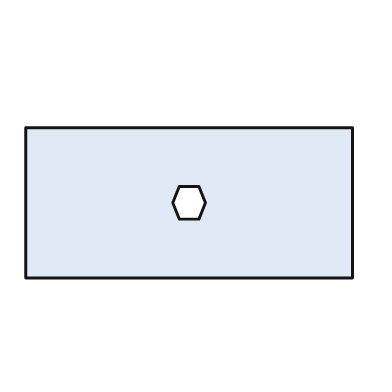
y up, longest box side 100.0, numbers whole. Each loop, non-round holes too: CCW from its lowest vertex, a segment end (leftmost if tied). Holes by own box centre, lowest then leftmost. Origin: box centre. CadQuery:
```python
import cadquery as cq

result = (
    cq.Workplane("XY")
    .moveTo(-50.0, -23.0)
    .lineTo(50.0, -23.0)
    .lineTo(50.0, 23.0)
    .lineTo(-50.0, 23.0)
    .close()
    .moveTo(-3.0, -5.0)
    .lineTo(3.0, -5.0)
    .lineTo(5.0, 0.0)
    .lineTo(3.0, 5.0)
    .lineTo(-3.0, 5.0)
    .lineTo(-5.0, 0.0)
    .close()
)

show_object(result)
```